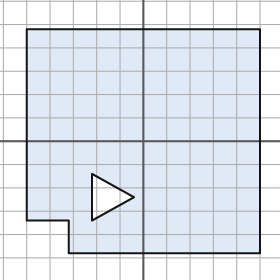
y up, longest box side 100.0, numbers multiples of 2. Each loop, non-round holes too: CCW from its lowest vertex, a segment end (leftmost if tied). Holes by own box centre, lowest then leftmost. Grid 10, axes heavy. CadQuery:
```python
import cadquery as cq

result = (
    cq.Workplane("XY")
    .moveTo(-32.0, -48.0)
    .lineTo(50.0, -48.0)
    .lineTo(50.0, 48.0)
    .lineTo(-50.0, 48.0)
    .lineTo(-50.0, -34.0)
    .lineTo(-32.0, -34.0)
    .close()
    .moveTo(-22.0, -34.0)
    .lineTo(-4.0, -24.0)
    .lineTo(-22.0, -14.0)
    .close()
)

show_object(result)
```